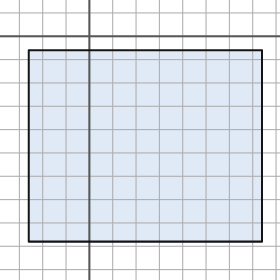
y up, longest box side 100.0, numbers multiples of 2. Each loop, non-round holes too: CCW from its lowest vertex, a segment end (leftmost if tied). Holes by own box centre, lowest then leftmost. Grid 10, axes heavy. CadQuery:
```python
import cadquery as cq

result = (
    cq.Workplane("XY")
    .moveTo(-26.0, -88.0)
    .lineTo(74.0, -88.0)
    .lineTo(74.0, -6.0)
    .lineTo(-26.0, -6.0)
    .close()
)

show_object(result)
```